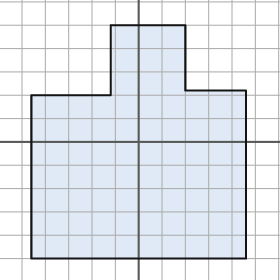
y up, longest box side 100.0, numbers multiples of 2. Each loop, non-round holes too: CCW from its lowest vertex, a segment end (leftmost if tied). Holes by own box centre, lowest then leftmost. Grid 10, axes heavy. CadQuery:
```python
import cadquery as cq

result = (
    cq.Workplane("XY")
    .moveTo(-46.0, -50.0)
    .lineTo(46.0, -50.0)
    .lineTo(46.0, 22.0)
    .lineTo(20.0, 22.0)
    .lineTo(20.0, 50.0)
    .lineTo(-12.0, 50.0)
    .lineTo(-12.0, 20.0)
    .lineTo(-46.0, 20.0)
    .close()
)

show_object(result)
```